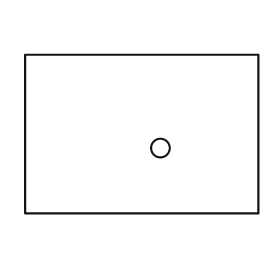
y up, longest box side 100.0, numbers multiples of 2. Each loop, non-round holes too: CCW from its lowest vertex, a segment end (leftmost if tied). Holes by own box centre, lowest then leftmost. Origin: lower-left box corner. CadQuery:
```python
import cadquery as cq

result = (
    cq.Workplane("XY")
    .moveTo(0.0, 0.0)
    .lineTo(100.0, 0.0)
    .lineTo(100.0, 68.0)
    .lineTo(0.0, 68.0)
    .close()
    .moveTo(58.0, 28.0)
    .circle(4.0)
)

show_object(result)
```